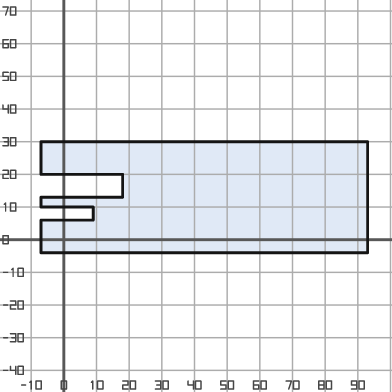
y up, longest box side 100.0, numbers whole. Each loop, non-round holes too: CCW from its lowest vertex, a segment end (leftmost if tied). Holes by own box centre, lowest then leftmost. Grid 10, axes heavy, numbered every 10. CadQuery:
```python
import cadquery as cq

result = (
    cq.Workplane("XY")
    .moveTo(-7.0, -4.0)
    .lineTo(93.0, -4.0)
    .lineTo(93.0, 30.0)
    .lineTo(-7.0, 30.0)
    .lineTo(-7.0, 20.0)
    .lineTo(18.0, 20.0)
    .lineTo(18.0, 13.0)
    .lineTo(-7.0, 13.0)
    .lineTo(-7.0, 10.0)
    .lineTo(9.0, 10.0)
    .lineTo(9.0, 6.0)
    .lineTo(-7.0, 6.0)
    .close()
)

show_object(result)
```